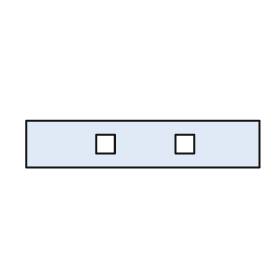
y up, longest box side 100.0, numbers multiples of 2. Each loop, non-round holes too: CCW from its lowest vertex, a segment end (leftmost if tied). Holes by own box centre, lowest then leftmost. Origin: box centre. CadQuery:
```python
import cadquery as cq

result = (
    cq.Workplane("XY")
    .moveTo(-50.0, -10.0)
    .lineTo(50.0, -10.0)
    .lineTo(50.0, 10.0)
    .lineTo(-50.0, 10.0)
    .close()
    .moveTo(-20.0, -4.0)
    .lineTo(-12.0, -4.0)
    .lineTo(-12.0, 4.0)
    .lineTo(-20.0, 4.0)
    .close()
    .moveTo(14.0, -4.0)
    .lineTo(22.0, -4.0)
    .lineTo(22.0, 4.0)
    .lineTo(14.0, 4.0)
    .close()
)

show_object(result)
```